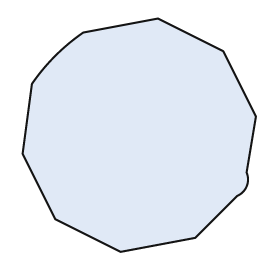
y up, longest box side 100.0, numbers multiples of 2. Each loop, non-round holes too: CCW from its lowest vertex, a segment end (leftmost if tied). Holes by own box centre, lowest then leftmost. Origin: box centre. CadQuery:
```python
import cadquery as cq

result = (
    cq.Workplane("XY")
    .moveTo(-8.0, -50.0)
    .lineTo(24.0, -44.0)
    .lineTo(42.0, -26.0)
    .threePointArc((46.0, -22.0), (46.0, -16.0))
    .lineTo(50.0, 8.0)
    .lineTo(36.0, 36.0)
    .lineTo(8.0, 50.0)
    .lineTo(-24.0, 44.0)
    .threePointArc((-36.0, 34.0), (-46.0, 22.0))
    .lineTo(-50.0, -8.0)
    .lineTo(-36.0, -36.0)
    .close()
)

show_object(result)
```